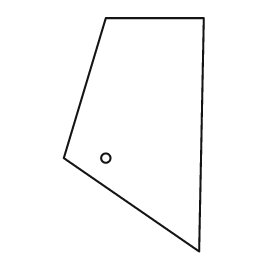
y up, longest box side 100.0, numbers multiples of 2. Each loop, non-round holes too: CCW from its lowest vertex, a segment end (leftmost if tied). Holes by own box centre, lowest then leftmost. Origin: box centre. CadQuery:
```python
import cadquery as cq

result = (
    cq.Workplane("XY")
    .moveTo(28.0, -50.0)
    .lineTo(30.0, 50.0)
    .lineTo(-12.0, 50.0)
    .lineTo(-30.0, -10.0)
    .close()
    .moveTo(-12.0, -10.0)
    .circle(2.0)
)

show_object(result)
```